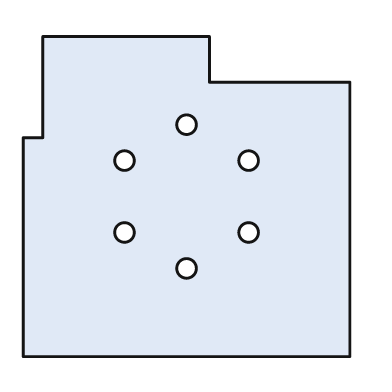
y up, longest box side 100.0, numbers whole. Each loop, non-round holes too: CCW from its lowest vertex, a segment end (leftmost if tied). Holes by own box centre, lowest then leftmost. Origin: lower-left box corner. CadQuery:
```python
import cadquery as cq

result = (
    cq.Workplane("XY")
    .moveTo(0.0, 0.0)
    .lineTo(100.0, 0.0)
    .lineTo(100.0, 84.0)
    .lineTo(57.0, 84.0)
    .lineTo(57.0, 98.0)
    .lineTo(6.0, 98.0)
    .lineTo(6.0, 67.0)
    .lineTo(0.0, 67.0)
    .close()
    .moveTo(50.0, 27.0)
    .circle(3.0)
    .moveTo(31.0, 38.0)
    .circle(3.0)
    .moveTo(69.0, 38.0)
    .circle(3.0)
    .moveTo(31.0, 60.0)
    .circle(3.0)
    .moveTo(69.0, 60.0)
    .circle(3.0)
    .moveTo(50.0, 71.0)
    .circle(3.0)
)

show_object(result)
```